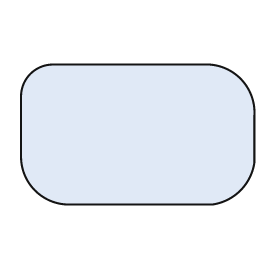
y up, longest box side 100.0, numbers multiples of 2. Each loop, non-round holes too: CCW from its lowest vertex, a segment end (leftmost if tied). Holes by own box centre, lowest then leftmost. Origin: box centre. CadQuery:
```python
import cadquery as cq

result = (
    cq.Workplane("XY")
    .moveTo(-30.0, -30.0)
    .lineTo(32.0, -30.0)
    .threePointArc((44.0, -24.0), (50.0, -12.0))
    .lineTo(50.0, 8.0)
    .threePointArc((44.0, 24.0), (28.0, 30.0))
    .lineTo(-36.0, 30.0)
    .threePointArc((-46.0, 26.0), (-50.0, 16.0))
    .lineTo(-50.0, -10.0)
    .threePointArc((-44.0, -24.0), (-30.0, -30.0))
    .close()
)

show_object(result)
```